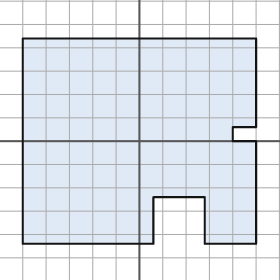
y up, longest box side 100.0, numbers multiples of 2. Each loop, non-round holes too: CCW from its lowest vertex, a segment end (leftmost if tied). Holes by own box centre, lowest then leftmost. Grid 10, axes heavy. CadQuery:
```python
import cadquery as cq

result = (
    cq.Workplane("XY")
    .moveTo(-50.0, -44.0)
    .lineTo(6.0, -44.0)
    .lineTo(6.0, -24.0)
    .lineTo(28.0, -24.0)
    .lineTo(28.0, -44.0)
    .lineTo(50.0, -44.0)
    .lineTo(50.0, 0.0)
    .lineTo(40.0, 0.0)
    .lineTo(40.0, 6.0)
    .lineTo(50.0, 6.0)
    .lineTo(50.0, 44.0)
    .lineTo(-50.0, 44.0)
    .close()
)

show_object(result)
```